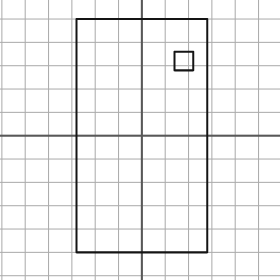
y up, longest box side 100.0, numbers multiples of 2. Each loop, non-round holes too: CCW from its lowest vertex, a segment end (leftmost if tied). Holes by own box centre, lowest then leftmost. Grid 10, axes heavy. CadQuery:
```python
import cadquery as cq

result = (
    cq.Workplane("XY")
    .moveTo(-28.0, -50.0)
    .lineTo(28.0, -50.0)
    .lineTo(28.0, 50.0)
    .lineTo(-28.0, 50.0)
    .close()
    .moveTo(14.0, 28.0)
    .lineTo(22.0, 28.0)
    .lineTo(22.0, 36.0)
    .lineTo(14.0, 36.0)
    .close()
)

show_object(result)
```